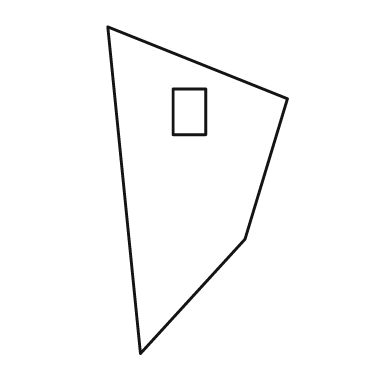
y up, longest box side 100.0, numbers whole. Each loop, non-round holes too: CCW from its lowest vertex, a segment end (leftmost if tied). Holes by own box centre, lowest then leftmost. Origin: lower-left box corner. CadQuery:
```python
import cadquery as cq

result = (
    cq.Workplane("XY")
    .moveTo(10.0, 0.0)
    .lineTo(42.0, 35.0)
    .lineTo(55.0, 78.0)
    .lineTo(0.0, 100.0)
    .close()
    .moveTo(20.0, 67.0)
    .lineTo(30.0, 67.0)
    .lineTo(30.0, 81.0)
    .lineTo(20.0, 81.0)
    .close()
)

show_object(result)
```